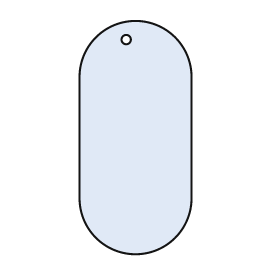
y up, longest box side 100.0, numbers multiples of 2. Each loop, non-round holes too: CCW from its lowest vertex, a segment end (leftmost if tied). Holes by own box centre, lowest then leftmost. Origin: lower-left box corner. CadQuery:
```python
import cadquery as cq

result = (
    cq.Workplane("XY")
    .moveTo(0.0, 24.0)
    .threePointArc((24.0, 0.0), (48.0, 24.0))
    .lineTo(48.0, 76.0)
    .threePointArc((24.0, 100.0), (0.0, 76.0))
    .close()
    .moveTo(20.0, 92.0)
    .circle(2.0)
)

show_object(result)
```